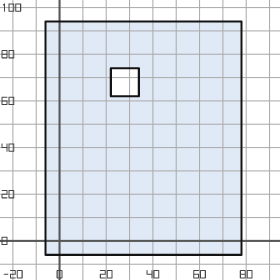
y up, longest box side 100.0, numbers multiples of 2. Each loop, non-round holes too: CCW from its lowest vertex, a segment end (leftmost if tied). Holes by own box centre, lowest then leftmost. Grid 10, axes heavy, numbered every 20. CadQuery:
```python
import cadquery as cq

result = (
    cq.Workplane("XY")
    .moveTo(-6.0, -6.0)
    .lineTo(78.0, -6.0)
    .lineTo(78.0, 94.0)
    .lineTo(-6.0, 94.0)
    .close()
    .moveTo(22.0, 62.0)
    .lineTo(34.0, 62.0)
    .lineTo(34.0, 74.0)
    .lineTo(22.0, 74.0)
    .close()
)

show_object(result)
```